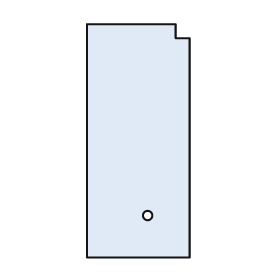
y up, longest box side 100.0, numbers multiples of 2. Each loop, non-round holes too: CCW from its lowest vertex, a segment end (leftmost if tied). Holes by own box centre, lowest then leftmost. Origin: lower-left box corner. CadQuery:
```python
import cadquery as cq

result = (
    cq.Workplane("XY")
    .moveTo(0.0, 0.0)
    .lineTo(44.0, 0.0)
    .lineTo(44.0, 94.0)
    .lineTo(38.0, 94.0)
    .lineTo(38.0, 100.0)
    .lineTo(0.0, 100.0)
    .close()
    .moveTo(26.0, 18.0)
    .circle(2.0)
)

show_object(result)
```